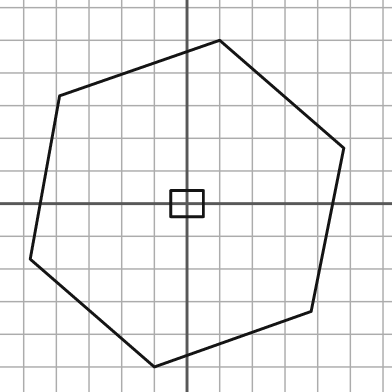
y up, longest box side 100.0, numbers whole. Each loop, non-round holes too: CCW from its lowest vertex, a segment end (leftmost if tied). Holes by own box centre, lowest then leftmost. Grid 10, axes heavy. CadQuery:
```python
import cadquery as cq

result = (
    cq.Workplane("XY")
    .moveTo(-10.0, -50.0)
    .lineTo(38.0, -33.0)
    .lineTo(48.0, 17.0)
    .lineTo(10.0, 50.0)
    .lineTo(-39.0, 33.0)
    .lineTo(-48.0, -17.0)
    .close()
    .moveTo(-5.0, -4.0)
    .lineTo(5.0, -4.0)
    .lineTo(5.0, 4.0)
    .lineTo(-5.0, 4.0)
    .close()
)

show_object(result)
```